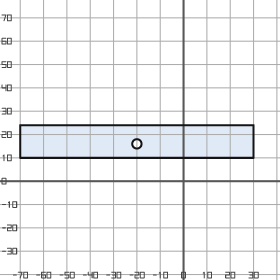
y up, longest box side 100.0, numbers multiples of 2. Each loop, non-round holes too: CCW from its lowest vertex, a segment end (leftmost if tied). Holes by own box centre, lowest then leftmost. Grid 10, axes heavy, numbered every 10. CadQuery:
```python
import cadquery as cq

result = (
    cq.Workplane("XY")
    .moveTo(-70.0, 10.0)
    .lineTo(30.0, 10.0)
    .lineTo(30.0, 24.0)
    .lineTo(-70.0, 24.0)
    .close()
    .moveTo(-20.0, 16.0)
    .circle(2.0)
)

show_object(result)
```